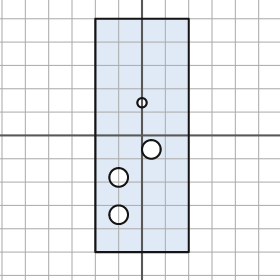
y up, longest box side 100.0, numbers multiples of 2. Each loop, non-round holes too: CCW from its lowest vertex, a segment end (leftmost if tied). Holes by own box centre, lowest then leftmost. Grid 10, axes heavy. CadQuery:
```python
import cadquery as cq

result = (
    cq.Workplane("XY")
    .moveTo(-20.0, -50.0)
    .lineTo(20.0, -50.0)
    .lineTo(20.0, 50.0)
    .lineTo(-20.0, 50.0)
    .close()
    .moveTo(-10.0, -34.0)
    .circle(4.0)
    .moveTo(-10.0, -18.0)
    .circle(4.0)
    .moveTo(4.0, -6.0)
    .circle(4.0)
    .moveTo(0.0, 14.0)
    .circle(2.0)
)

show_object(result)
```